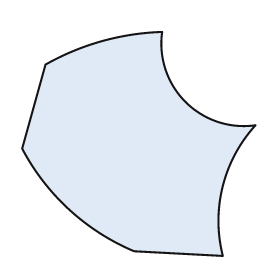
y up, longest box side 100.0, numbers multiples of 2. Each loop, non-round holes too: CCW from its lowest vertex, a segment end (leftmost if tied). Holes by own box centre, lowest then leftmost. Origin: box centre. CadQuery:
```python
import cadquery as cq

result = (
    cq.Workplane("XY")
    .moveTo(36.0, -48.0)
    .threePointArc((36.0, -18.0), (50.0, 8.0))
    .threePointArc((20.0, 18.0), (10.0, 48.0))
    .threePointArc((-16.0, 44.0), (-40.0, 34.0))
    .lineTo(-50.0, -2.0)
    .threePointArc((-30.0, -28.0), (-2.0, -46.0))
    .close()
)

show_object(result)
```